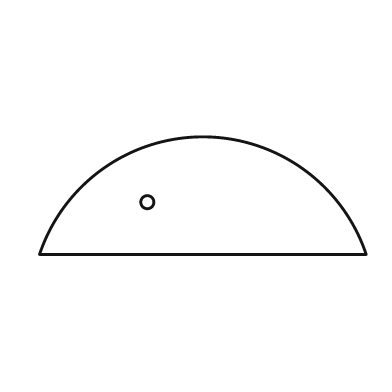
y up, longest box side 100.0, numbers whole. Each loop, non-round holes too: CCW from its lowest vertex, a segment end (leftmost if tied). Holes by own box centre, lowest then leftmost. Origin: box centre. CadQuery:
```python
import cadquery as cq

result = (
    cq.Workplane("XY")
    .moveTo(-50.0, -18.0)
    .lineTo(50.0, -18.0)
    .threePointArc((0.0, 18.0), (-50.0, -18.0))
    .close()
    .moveTo(-17.0, -2.0)
    .circle(2.0)
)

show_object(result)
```